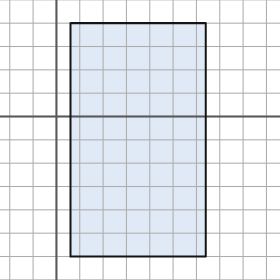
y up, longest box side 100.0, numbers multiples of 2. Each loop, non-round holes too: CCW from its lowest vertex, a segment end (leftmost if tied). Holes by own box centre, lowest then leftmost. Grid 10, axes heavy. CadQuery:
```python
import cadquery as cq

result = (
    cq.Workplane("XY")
    .moveTo(6.0, -60.0)
    .lineTo(64.0, -60.0)
    .lineTo(64.0, 40.0)
    .lineTo(6.0, 40.0)
    .close()
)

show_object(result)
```